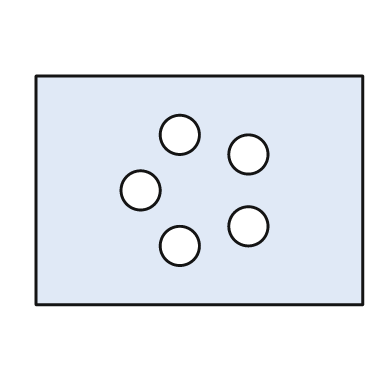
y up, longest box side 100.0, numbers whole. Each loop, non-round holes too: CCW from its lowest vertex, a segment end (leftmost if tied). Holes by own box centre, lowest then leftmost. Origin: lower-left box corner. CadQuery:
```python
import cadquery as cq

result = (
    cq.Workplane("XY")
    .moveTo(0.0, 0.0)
    .lineTo(100.0, 0.0)
    .lineTo(100.0, 70.0)
    .lineTo(0.0, 70.0)
    .close()
    .moveTo(44.0, 18.0)
    .circle(6.0)
    .moveTo(65.0, 24.0)
    .circle(6.0)
    .moveTo(32.0, 35.0)
    .circle(6.0)
    .moveTo(65.0, 46.0)
    .circle(6.0)
    .moveTo(44.0, 52.0)
    .circle(6.0)
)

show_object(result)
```